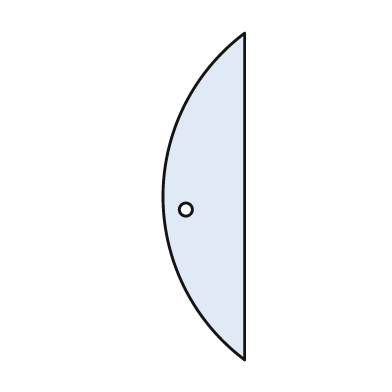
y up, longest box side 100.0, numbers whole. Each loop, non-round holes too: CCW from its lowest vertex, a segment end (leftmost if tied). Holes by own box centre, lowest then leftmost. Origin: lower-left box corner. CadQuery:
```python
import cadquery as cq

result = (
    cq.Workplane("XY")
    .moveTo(25.0, 0.0)
    .lineTo(25.0, 100.0)
    .threePointArc((0.0, 50.0), (25.0, 0.0))
    .close()
    .moveTo(7.0, 46.0)
    .circle(2.0)
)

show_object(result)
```